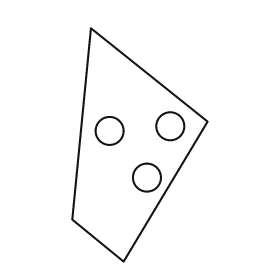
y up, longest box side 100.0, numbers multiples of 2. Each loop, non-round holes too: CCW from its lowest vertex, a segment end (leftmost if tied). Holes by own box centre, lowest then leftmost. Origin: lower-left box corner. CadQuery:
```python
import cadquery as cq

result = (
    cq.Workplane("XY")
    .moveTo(22.0, 0.0)
    .lineTo(58.0, 60.0)
    .lineTo(8.0, 100.0)
    .lineTo(0.0, 18.0)
    .close()
    .moveTo(32.0, 36.0)
    .circle(6.0)
    .moveTo(16.0, 56.0)
    .circle(6.0)
    .moveTo(42.0, 58.0)
    .circle(6.0)
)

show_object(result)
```